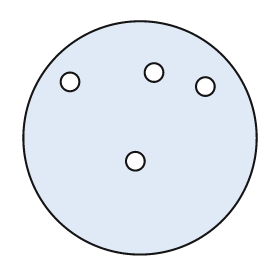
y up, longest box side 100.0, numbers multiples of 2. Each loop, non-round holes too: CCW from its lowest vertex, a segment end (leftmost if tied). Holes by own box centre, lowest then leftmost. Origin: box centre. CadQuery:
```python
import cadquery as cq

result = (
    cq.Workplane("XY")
    .moveTo(0.0, 0.0)
    .circle(50.0)
    .moveTo(-2.0, -10.0)
    .circle(4.0)
    .moveTo(28.0, 22.0)
    .circle(4.0)
    .moveTo(-30.0, 24.0)
    .circle(4.0)
    .moveTo(6.0, 28.0)
    .circle(4.0)
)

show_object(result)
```